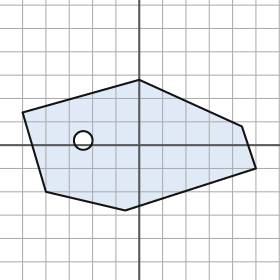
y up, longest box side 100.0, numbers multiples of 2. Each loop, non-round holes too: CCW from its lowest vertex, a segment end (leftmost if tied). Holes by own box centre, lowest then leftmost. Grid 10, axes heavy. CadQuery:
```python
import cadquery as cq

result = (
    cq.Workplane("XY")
    .moveTo(-6.0, -28.0)
    .lineTo(50.0, -10.0)
    .lineTo(44.0, 8.0)
    .lineTo(0.0, 28.0)
    .lineTo(-50.0, 14.0)
    .lineTo(-40.0, -20.0)
    .close()
    .moveTo(-24.0, 2.0)
    .circle(4.0)
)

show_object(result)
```